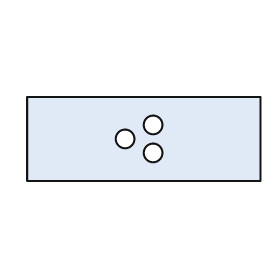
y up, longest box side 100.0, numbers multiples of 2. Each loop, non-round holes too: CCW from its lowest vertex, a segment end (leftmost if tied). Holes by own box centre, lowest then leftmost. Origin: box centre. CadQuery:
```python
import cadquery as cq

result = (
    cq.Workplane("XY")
    .moveTo(-50.0, -18.0)
    .lineTo(50.0, -18.0)
    .lineTo(50.0, 18.0)
    .lineTo(-50.0, 18.0)
    .close()
    .moveTo(4.0, -6.0)
    .circle(4.0)
    .moveTo(-8.0, 0.0)
    .circle(4.0)
    .moveTo(4.0, 6.0)
    .circle(4.0)
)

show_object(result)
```